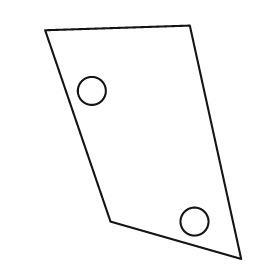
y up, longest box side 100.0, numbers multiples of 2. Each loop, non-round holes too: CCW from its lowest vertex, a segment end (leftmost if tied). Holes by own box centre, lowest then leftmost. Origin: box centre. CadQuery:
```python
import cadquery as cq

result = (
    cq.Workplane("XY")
    .moveTo(42.0, -50.0)
    .lineTo(20.0, 50.0)
    .lineTo(-42.0, 48.0)
    .lineTo(-14.0, -34.0)
    .close()
    .moveTo(22.0, -34.0)
    .circle(6.0)
    .moveTo(-22.0, 22.0)
    .circle(6.0)
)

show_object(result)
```